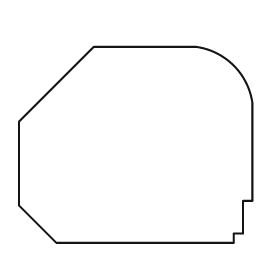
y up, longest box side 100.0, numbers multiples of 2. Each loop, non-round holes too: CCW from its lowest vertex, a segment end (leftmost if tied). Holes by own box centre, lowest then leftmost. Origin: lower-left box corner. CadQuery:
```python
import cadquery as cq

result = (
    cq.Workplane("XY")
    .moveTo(16.0, 0.0)
    .lineTo(92.0, 0.0)
    .lineTo(92.0, 4.0)
    .lineTo(96.0, 4.0)
    .lineTo(96.0, 18.0)
    .lineTo(100.0, 18.0)
    .lineTo(100.0, 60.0)
    .threePointArc((92.0, 76.0), (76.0, 84.0))
    .lineTo(32.0, 84.0)
    .lineTo(0.0, 52.0)
    .lineTo(0.0, 16.0)
    .close()
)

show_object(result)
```